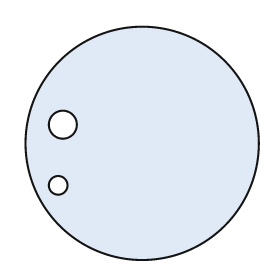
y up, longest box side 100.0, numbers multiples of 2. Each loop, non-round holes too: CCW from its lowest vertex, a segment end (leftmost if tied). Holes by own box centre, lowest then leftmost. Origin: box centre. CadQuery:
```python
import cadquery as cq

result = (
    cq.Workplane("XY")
    .moveTo(0.0, 0.0)
    .circle(50.0)
    .moveTo(-36.0, -18.0)
    .circle(4.0)
    .moveTo(-34.0, 8.0)
    .circle(6.0)
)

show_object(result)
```